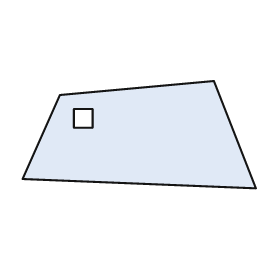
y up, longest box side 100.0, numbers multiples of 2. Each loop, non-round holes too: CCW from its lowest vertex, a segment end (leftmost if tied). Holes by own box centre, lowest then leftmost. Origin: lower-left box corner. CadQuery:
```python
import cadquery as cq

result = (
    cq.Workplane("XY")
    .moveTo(100.0, 0.0)
    .lineTo(82.0, 46.0)
    .lineTo(16.0, 40.0)
    .lineTo(0.0, 4.0)
    .close()
    .moveTo(22.0, 26.0)
    .lineTo(30.0, 26.0)
    .lineTo(30.0, 34.0)
    .lineTo(22.0, 34.0)
    .close()
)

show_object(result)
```